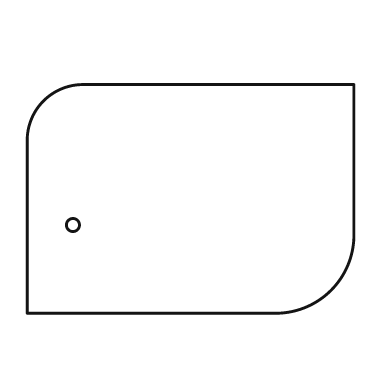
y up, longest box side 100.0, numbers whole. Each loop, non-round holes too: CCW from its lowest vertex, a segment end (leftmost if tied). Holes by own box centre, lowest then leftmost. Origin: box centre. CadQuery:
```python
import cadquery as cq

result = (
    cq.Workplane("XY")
    .moveTo(-50.0, -35.0)
    .lineTo(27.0, -35.0)
    .threePointArc((43.0, -28.0), (50.0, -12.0))
    .lineTo(50.0, 35.0)
    .lineTo(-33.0, 35.0)
    .threePointArc((-45.0, 30.0), (-50.0, 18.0))
    .close()
    .moveTo(-36.0, -8.0)
    .circle(2.0)
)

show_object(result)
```